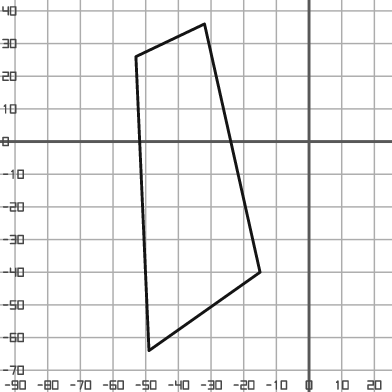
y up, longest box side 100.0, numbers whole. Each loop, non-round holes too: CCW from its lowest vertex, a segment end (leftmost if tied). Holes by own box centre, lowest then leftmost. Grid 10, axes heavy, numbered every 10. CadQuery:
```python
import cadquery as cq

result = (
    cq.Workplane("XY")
    .moveTo(-49.0, -64.0)
    .lineTo(-15.0, -40.0)
    .lineTo(-32.0, 36.0)
    .lineTo(-53.0, 26.0)
    .close()
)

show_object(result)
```